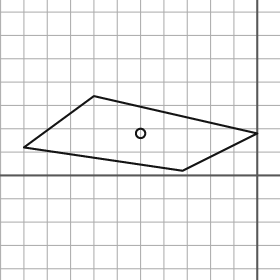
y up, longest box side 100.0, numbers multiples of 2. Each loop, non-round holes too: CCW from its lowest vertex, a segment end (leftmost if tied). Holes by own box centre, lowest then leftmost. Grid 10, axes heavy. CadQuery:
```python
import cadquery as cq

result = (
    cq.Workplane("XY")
    .moveTo(-32.0, 2.0)
    .lineTo(0.0, 18.0)
    .lineTo(-70.0, 34.0)
    .lineTo(-100.0, 12.0)
    .close()
    .moveTo(-50.0, 18.0)
    .circle(2.0)
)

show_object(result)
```